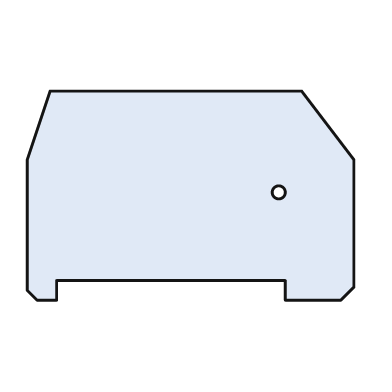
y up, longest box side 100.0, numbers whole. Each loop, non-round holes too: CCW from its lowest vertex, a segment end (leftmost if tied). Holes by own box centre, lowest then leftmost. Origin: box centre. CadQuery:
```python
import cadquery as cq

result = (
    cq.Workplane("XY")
    .moveTo(-47.0, -32.0)
    .lineTo(-41.0, -32.0)
    .lineTo(-41.0, -26.0)
    .lineTo(29.0, -26.0)
    .lineTo(29.0, -32.0)
    .lineTo(46.0, -32.0)
    .lineTo(50.0, -28.0)
    .lineTo(50.0, 11.0)
    .lineTo(34.0, 32.0)
    .lineTo(-43.0, 32.0)
    .lineTo(-50.0, 11.0)
    .lineTo(-50.0, -29.0)
    .close()
    .moveTo(27.0, 1.0)
    .circle(2.0)
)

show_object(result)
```